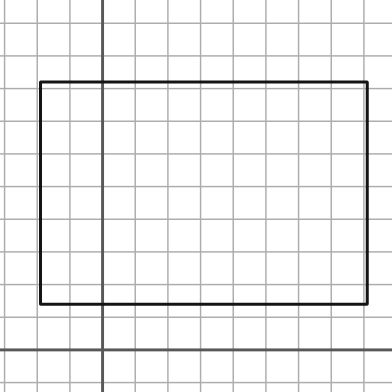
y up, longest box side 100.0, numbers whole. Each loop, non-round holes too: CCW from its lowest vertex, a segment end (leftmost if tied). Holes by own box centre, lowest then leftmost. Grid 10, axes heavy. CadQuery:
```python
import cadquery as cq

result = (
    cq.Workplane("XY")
    .moveTo(-19.0, 14.0)
    .lineTo(81.0, 14.0)
    .lineTo(81.0, 82.0)
    .lineTo(-19.0, 82.0)
    .close()
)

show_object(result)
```